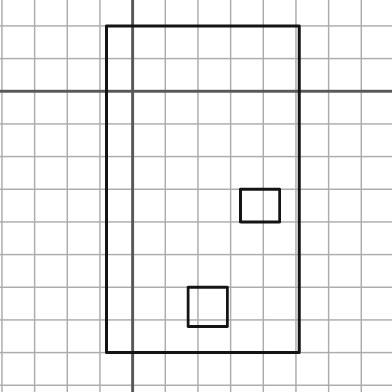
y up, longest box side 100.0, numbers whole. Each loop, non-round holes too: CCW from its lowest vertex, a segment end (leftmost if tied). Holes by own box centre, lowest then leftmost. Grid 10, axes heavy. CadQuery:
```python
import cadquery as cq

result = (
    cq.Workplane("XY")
    .moveTo(-8.0, -80.0)
    .lineTo(51.0, -80.0)
    .lineTo(51.0, 20.0)
    .lineTo(-8.0, 20.0)
    .close()
    .moveTo(17.0, -72.0)
    .lineTo(29.0, -72.0)
    .lineTo(29.0, -60.0)
    .lineTo(17.0, -60.0)
    .close()
    .moveTo(33.0, -40.0)
    .lineTo(45.0, -40.0)
    .lineTo(45.0, -30.0)
    .lineTo(33.0, -30.0)
    .close()
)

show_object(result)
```